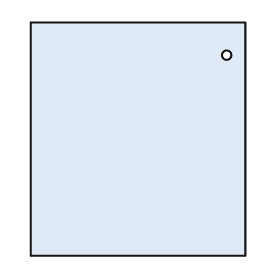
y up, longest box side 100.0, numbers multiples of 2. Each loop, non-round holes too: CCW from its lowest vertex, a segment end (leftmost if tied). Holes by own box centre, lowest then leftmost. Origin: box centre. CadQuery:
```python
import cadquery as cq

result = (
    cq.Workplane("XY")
    .moveTo(-46.0, -50.0)
    .lineTo(46.0, -50.0)
    .lineTo(46.0, 50.0)
    .lineTo(-46.0, 50.0)
    .close()
    .moveTo(38.0, 36.0)
    .circle(2.0)
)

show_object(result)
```